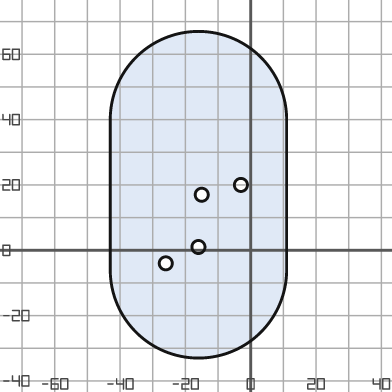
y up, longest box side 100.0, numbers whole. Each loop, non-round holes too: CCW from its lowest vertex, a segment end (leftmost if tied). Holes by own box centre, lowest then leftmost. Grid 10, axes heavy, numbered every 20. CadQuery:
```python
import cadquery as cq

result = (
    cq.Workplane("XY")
    .moveTo(-43.0, -6.0)
    .threePointArc((-16.0, -33.0), (11.0, -6.0))
    .lineTo(11.0, 40.0)
    .threePointArc((-16.0, 67.0), (-43.0, 40.0))
    .close()
    .moveTo(-26.0, -4.0)
    .circle(2.0)
    .moveTo(-16.0, 1.0)
    .circle(2.0)
    .moveTo(-15.0, 17.0)
    .circle(2.0)
    .moveTo(-3.0, 20.0)
    .circle(2.0)
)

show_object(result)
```